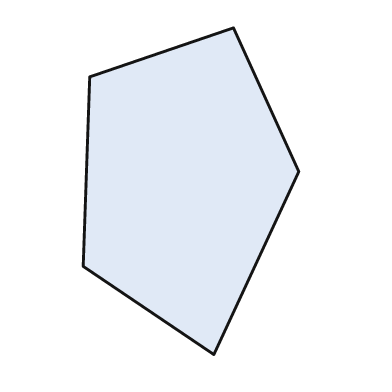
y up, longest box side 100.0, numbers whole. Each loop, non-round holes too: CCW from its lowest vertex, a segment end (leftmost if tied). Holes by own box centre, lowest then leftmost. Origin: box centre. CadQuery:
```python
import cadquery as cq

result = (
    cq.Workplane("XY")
    .moveTo(7.0, -50.0)
    .lineTo(33.0, 6.0)
    .lineTo(13.0, 50.0)
    .lineTo(-31.0, 35.0)
    .lineTo(-33.0, -23.0)
    .close()
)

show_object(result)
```